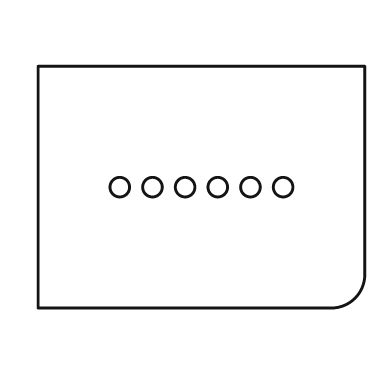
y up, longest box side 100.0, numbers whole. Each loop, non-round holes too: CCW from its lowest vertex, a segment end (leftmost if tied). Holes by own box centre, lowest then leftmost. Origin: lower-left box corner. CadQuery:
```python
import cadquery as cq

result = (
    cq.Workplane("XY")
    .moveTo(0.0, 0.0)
    .lineTo(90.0, 0.0)
    .threePointArc((97.0, 3.0), (100.0, 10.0))
    .lineTo(100.0, 74.0)
    .lineTo(0.0, 74.0)
    .close()
    .moveTo(25.0, 37.0)
    .circle(3.0)
    .moveTo(35.0, 37.0)
    .circle(3.0)
    .moveTo(45.0, 37.0)
    .circle(3.0)
    .moveTo(55.0, 37.0)
    .circle(3.0)
    .moveTo(65.0, 37.0)
    .circle(3.0)
    .moveTo(75.0, 37.0)
    .circle(3.0)
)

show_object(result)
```